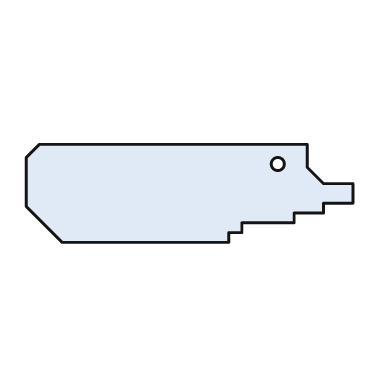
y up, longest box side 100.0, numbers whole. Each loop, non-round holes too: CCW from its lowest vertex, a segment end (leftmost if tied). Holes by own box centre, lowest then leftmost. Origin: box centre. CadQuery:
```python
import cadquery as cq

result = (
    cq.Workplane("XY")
    .moveTo(-39.0, -15.0)
    .lineTo(12.0, -15.0)
    .lineTo(12.0, -12.0)
    .lineTo(16.0, -12.0)
    .lineTo(16.0, -9.0)
    .lineTo(32.0, -9.0)
    .lineTo(32.0, -6.0)
    .lineTo(41.0, -6.0)
    .lineTo(41.0, -3.0)
    .lineTo(50.0, -3.0)
    .lineTo(50.0, 3.0)
    .lineTo(41.0, 3.0)
    .lineTo(36.0, 8.0)
    .lineTo(36.0, 15.0)
    .lineTo(-46.0, 15.0)
    .lineTo(-50.0, 11.0)
    .lineTo(-50.0, -4.0)
    .close()
    .moveTo(27.0, 9.0)
    .circle(2.0)
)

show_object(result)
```